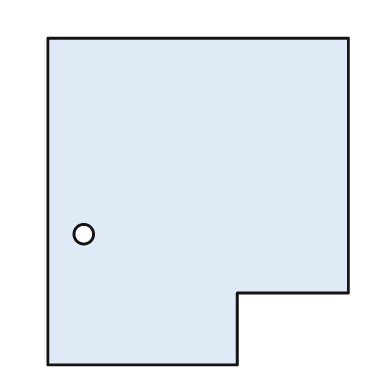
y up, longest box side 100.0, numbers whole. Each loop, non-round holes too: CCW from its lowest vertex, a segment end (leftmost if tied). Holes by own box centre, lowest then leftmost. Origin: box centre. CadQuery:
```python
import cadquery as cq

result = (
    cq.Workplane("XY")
    .moveTo(-46.0, -50.0)
    .lineTo(12.0, -50.0)
    .lineTo(12.0, -28.0)
    .lineTo(46.0, -28.0)
    .lineTo(46.0, 50.0)
    .lineTo(-46.0, 50.0)
    .close()
    .moveTo(-35.0, -10.0)
    .circle(3.0)
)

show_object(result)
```